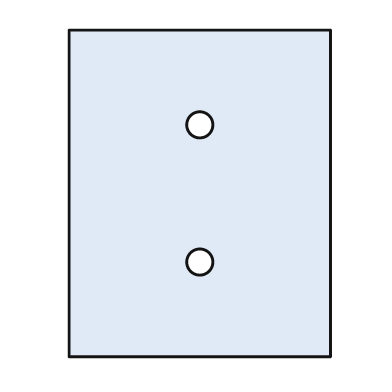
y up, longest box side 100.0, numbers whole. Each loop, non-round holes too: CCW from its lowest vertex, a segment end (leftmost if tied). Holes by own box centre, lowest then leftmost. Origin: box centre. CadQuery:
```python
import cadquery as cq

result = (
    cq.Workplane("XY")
    .moveTo(-40.0, -50.0)
    .lineTo(40.0, -50.0)
    .lineTo(40.0, 50.0)
    .lineTo(-40.0, 50.0)
    .close()
    .moveTo(0.0, -21.0)
    .circle(4.0)
    .moveTo(0.0, 21.0)
    .circle(4.0)
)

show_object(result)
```